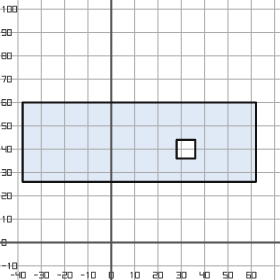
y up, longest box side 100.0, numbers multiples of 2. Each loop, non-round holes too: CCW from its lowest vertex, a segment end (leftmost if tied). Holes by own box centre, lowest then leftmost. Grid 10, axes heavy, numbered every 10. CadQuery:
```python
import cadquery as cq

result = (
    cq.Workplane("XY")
    .moveTo(-38.0, 26.0)
    .lineTo(62.0, 26.0)
    .lineTo(62.0, 60.0)
    .lineTo(-38.0, 60.0)
    .close()
    .moveTo(28.0, 36.0)
    .lineTo(36.0, 36.0)
    .lineTo(36.0, 44.0)
    .lineTo(28.0, 44.0)
    .close()
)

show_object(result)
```